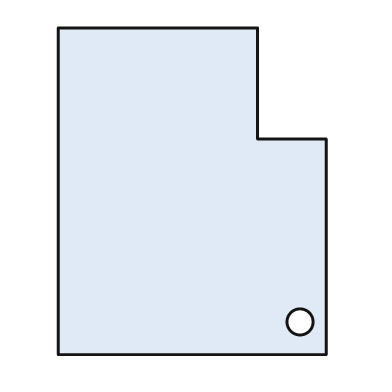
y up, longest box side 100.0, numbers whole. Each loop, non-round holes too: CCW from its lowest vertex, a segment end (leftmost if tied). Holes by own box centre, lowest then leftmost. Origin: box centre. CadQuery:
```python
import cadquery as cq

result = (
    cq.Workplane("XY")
    .moveTo(-41.0, -50.0)
    .lineTo(41.0, -50.0)
    .lineTo(41.0, 16.0)
    .lineTo(20.0, 16.0)
    .lineTo(20.0, 50.0)
    .lineTo(-41.0, 50.0)
    .close()
    .moveTo(33.0, -40.0)
    .circle(4.0)
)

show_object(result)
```